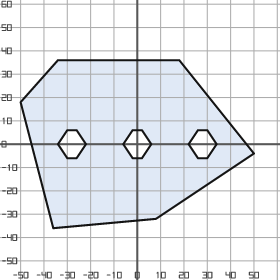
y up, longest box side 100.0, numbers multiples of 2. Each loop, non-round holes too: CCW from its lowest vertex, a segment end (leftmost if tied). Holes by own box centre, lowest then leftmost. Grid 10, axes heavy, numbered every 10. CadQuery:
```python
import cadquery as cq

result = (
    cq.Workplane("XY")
    .moveTo(-36.0, -36.0)
    .lineTo(8.0, -32.0)
    .lineTo(50.0, -4.0)
    .lineTo(18.0, 36.0)
    .lineTo(-34.0, 36.0)
    .lineTo(-50.0, 18.0)
    .close()
    .moveTo(-30.0, -6.0)
    .lineTo(-26.0, -6.0)
    .lineTo(-22.0, 0.0)
    .lineTo(-26.0, 6.0)
    .lineTo(-30.0, 6.0)
    .lineTo(-34.0, 0.0)
    .close()
    .moveTo(-2.0, -6.0)
    .lineTo(2.0, -6.0)
    .lineTo(6.0, 0.0)
    .lineTo(2.0, 6.0)
    .lineTo(-2.0, 6.0)
    .lineTo(-6.0, 0.0)
    .close()
    .moveTo(26.0, -6.0)
    .lineTo(30.0, -6.0)
    .lineTo(34.0, 0.0)
    .lineTo(30.0, 6.0)
    .lineTo(26.0, 6.0)
    .lineTo(22.0, 0.0)
    .close()
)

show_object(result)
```